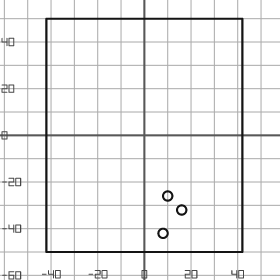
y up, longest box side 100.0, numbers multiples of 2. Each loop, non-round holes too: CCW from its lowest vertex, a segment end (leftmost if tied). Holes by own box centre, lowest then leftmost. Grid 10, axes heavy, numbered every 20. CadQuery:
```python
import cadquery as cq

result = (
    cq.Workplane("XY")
    .moveTo(-42.0, -50.0)
    .lineTo(42.0, -50.0)
    .lineTo(42.0, 50.0)
    .lineTo(-42.0, 50.0)
    .close()
    .moveTo(8.0, -42.0)
    .circle(2.0)
    .moveTo(16.0, -32.0)
    .circle(2.0)
    .moveTo(10.0, -26.0)
    .circle(2.0)
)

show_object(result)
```